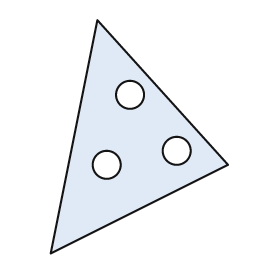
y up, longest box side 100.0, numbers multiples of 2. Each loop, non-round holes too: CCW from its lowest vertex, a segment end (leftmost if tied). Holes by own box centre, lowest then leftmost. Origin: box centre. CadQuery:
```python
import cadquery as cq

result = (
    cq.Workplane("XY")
    .moveTo(-38.0, -50.0)
    .lineTo(38.0, -12.0)
    .lineTo(-18.0, 50.0)
    .close()
    .moveTo(-14.0, -12.0)
    .circle(6.0)
    .moveTo(16.0, -6.0)
    .circle(6.0)
    .moveTo(-4.0, 18.0)
    .circle(6.0)
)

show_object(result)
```